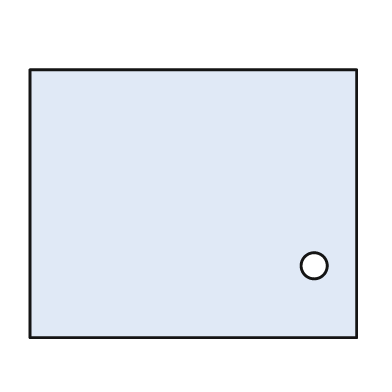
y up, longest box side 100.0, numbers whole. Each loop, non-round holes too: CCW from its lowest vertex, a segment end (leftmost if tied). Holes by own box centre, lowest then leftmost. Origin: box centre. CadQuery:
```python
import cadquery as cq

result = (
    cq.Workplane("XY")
    .moveTo(-50.0, -41.0)
    .lineTo(50.0, -41.0)
    .lineTo(50.0, 41.0)
    .lineTo(-50.0, 41.0)
    .close()
    .moveTo(37.0, -19.0)
    .circle(4.0)
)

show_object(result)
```